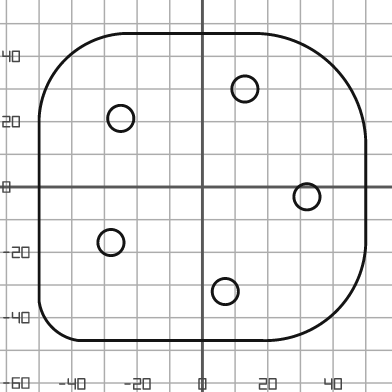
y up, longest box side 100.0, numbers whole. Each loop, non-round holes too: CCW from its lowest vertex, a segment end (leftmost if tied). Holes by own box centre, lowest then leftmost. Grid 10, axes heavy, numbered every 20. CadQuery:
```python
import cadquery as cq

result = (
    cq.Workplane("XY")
    .moveTo(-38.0, -47.0)
    .lineTo(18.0, -47.0)
    .threePointArc((41.0, -38.0), (50.0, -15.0))
    .lineTo(50.0, 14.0)
    .threePointArc((40.0, 37.0), (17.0, 47.0))
    .lineTo(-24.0, 47.0)
    .threePointArc((-42.0, 39.0), (-50.0, 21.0))
    .lineTo(-50.0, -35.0)
    .threePointArc((-46.0, -43.0), (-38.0, -47.0))
    .close()
    .moveTo(7.0, -32.0)
    .circle(4.0)
    .moveTo(-28.0, -17.0)
    .circle(4.0)
    .moveTo(32.0, -3.0)
    .circle(4.0)
    .moveTo(-25.0, 21.0)
    .circle(4.0)
    .moveTo(13.0, 30.0)
    .circle(4.0)
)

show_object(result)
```